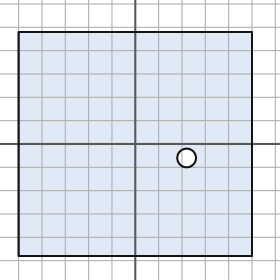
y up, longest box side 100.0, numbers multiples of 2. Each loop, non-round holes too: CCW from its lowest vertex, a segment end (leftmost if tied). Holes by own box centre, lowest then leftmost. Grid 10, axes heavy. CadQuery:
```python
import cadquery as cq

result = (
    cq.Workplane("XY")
    .moveTo(-50.0, -48.0)
    .lineTo(50.0, -48.0)
    .lineTo(50.0, 48.0)
    .lineTo(-50.0, 48.0)
    .close()
    .moveTo(22.0, -6.0)
    .circle(4.0)
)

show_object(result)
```